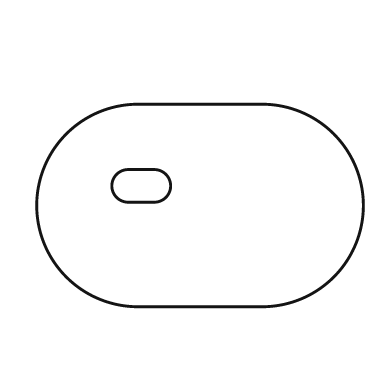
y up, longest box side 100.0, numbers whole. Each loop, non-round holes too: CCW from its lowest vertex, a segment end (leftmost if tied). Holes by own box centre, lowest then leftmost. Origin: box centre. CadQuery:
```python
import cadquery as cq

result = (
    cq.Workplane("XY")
    .moveTo(-19.0, -31.0)
    .lineTo(19.0, -31.0)
    .threePointArc((50.0, 0.0), (19.0, 31.0))
    .lineTo(-19.0, 31.0)
    .threePointArc((-50.0, 0.0), (-19.0, -31.0))
    .close()
    .moveTo(-22.0, 1.0)
    .lineTo(-14.0, 1.0)
    .threePointArc((-9.0, 6.0), (-14.0, 11.0))
    .lineTo(-22.0, 11.0)
    .threePointArc((-27.0, 6.0), (-22.0, 1.0))
    .close()
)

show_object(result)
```